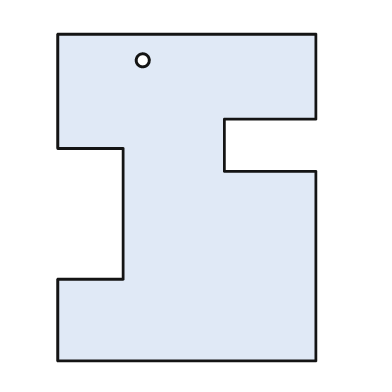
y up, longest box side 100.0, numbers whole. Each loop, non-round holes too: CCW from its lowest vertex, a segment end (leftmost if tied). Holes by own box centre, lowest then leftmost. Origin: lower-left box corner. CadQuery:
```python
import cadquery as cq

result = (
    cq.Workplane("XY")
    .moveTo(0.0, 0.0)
    .lineTo(79.0, 0.0)
    .lineTo(79.0, 58.0)
    .lineTo(51.0, 58.0)
    .lineTo(51.0, 74.0)
    .lineTo(79.0, 74.0)
    .lineTo(79.0, 100.0)
    .lineTo(0.0, 100.0)
    .lineTo(0.0, 65.0)
    .lineTo(20.0, 65.0)
    .lineTo(20.0, 25.0)
    .lineTo(0.0, 25.0)
    .close()
    .moveTo(26.0, 92.0)
    .circle(2.0)
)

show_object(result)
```